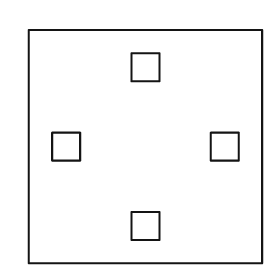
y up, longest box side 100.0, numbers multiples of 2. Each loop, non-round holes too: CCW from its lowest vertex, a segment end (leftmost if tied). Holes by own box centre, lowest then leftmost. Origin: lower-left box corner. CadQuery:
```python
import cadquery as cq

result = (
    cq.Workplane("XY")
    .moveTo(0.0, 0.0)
    .lineTo(100.0, 0.0)
    .lineTo(100.0, 100.0)
    .lineTo(0.0, 100.0)
    .close()
    .moveTo(44.0, 10.0)
    .lineTo(56.0, 10.0)
    .lineTo(56.0, 22.0)
    .lineTo(44.0, 22.0)
    .close()
    .moveTo(10.0, 44.0)
    .lineTo(22.0, 44.0)
    .lineTo(22.0, 56.0)
    .lineTo(10.0, 56.0)
    .close()
    .moveTo(78.0, 44.0)
    .lineTo(90.0, 44.0)
    .lineTo(90.0, 56.0)
    .lineTo(78.0, 56.0)
    .close()
    .moveTo(44.0, 78.0)
    .lineTo(56.0, 78.0)
    .lineTo(56.0, 90.0)
    .lineTo(44.0, 90.0)
    .close()
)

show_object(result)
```